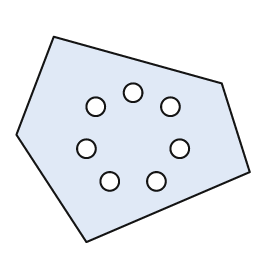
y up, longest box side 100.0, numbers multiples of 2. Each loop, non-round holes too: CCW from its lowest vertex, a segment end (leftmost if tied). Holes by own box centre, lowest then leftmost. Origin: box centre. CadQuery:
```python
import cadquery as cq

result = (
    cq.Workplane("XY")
    .moveTo(-20.0, -44.0)
    .lineTo(50.0, -14.0)
    .lineTo(38.0, 24.0)
    .lineTo(-34.0, 44.0)
    .lineTo(-50.0, 2.0)
    .close()
    .moveTo(-10.0, -18.0)
    .circle(4.0)
    .moveTo(10.0, -18.0)
    .circle(4.0)
    .moveTo(-20.0, -4.0)
    .circle(4.0)
    .moveTo(20.0, -4.0)
    .circle(4.0)
    .moveTo(-16.0, 14.0)
    .circle(4.0)
    .moveTo(16.0, 14.0)
    .circle(4.0)
    .moveTo(0.0, 20.0)
    .circle(4.0)
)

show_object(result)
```